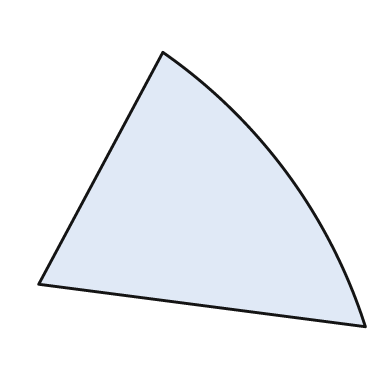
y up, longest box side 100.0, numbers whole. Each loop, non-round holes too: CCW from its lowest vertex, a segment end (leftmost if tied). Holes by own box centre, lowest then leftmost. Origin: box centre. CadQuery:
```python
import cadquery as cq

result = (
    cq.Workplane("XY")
    .moveTo(50.0, -42.0)
    .threePointArc((26.0, 5.0), (-12.0, 42.0))
    .lineTo(-50.0, -29.0)
    .close()
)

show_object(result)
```